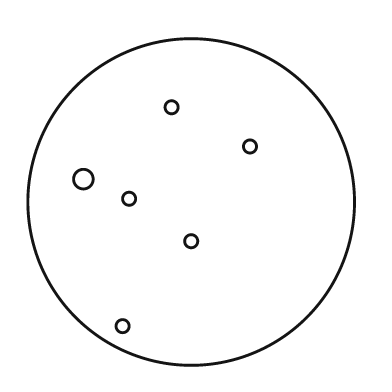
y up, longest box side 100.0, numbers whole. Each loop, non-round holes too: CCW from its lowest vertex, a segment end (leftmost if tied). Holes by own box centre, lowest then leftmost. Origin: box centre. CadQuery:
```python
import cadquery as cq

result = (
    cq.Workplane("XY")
    .moveTo(0.0, 0.0)
    .circle(50.0)
    .moveTo(-21.0, -38.0)
    .circle(2.0)
    .moveTo(0.0, -12.0)
    .circle(2.0)
    .moveTo(-19.0, 1.0)
    .circle(2.0)
    .moveTo(-33.0, 7.0)
    .circle(3.0)
    .moveTo(18.0, 17.0)
    .circle(2.0)
    .moveTo(-6.0, 29.0)
    .circle(2.0)
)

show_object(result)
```